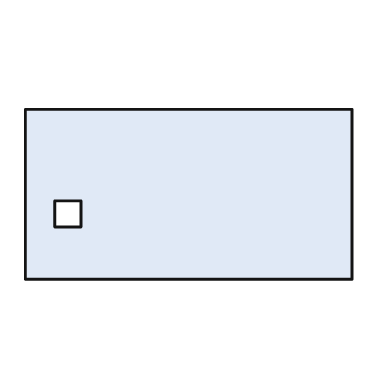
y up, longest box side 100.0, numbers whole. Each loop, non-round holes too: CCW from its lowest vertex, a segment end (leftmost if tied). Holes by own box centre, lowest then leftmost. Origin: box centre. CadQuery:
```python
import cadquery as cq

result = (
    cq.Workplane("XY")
    .moveTo(-50.0, -26.0)
    .lineTo(50.0, -26.0)
    .lineTo(50.0, 26.0)
    .lineTo(-50.0, 26.0)
    .close()
    .moveTo(-41.0, -10.0)
    .lineTo(-33.0, -10.0)
    .lineTo(-33.0, -2.0)
    .lineTo(-41.0, -2.0)
    .close()
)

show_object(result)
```